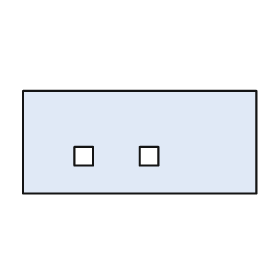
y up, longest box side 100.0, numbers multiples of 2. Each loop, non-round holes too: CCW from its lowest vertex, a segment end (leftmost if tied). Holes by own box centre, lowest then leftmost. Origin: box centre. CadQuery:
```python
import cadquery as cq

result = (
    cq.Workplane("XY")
    .moveTo(-50.0, -22.0)
    .lineTo(50.0, -22.0)
    .lineTo(50.0, 22.0)
    .lineTo(-50.0, 22.0)
    .close()
    .moveTo(-28.0, -10.0)
    .lineTo(-20.0, -10.0)
    .lineTo(-20.0, -2.0)
    .lineTo(-28.0, -2.0)
    .close()
    .moveTo(0.0, -10.0)
    .lineTo(8.0, -10.0)
    .lineTo(8.0, -2.0)
    .lineTo(0.0, -2.0)
    .close()
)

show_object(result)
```